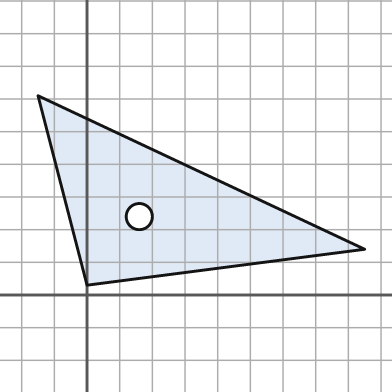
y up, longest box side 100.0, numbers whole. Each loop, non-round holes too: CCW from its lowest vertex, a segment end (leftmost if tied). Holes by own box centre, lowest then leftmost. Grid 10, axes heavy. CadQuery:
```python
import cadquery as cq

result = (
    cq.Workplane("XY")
    .moveTo(0.0, 3.0)
    .lineTo(85.0, 14.0)
    .lineTo(-15.0, 61.0)
    .close()
    .moveTo(16.0, 24.0)
    .circle(4.0)
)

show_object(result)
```